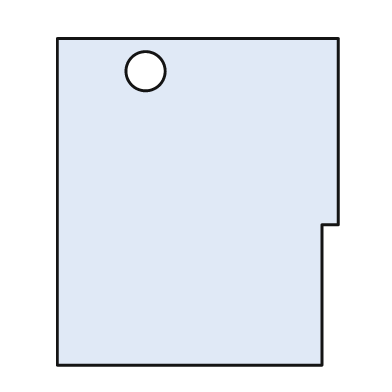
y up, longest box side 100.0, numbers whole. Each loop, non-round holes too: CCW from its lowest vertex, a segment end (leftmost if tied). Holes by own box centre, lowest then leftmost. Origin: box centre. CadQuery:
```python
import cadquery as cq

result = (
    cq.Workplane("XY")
    .moveTo(-43.0, -50.0)
    .lineTo(38.0, -50.0)
    .lineTo(38.0, -7.0)
    .lineTo(43.0, -7.0)
    .lineTo(43.0, 50.0)
    .lineTo(-43.0, 50.0)
    .close()
    .moveTo(-16.0, 40.0)
    .circle(6.0)
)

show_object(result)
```